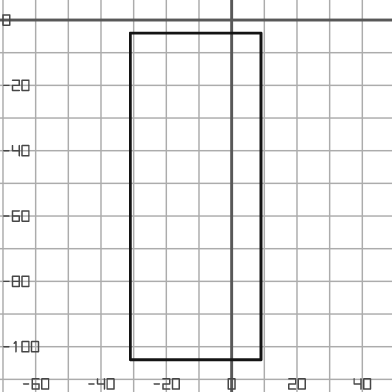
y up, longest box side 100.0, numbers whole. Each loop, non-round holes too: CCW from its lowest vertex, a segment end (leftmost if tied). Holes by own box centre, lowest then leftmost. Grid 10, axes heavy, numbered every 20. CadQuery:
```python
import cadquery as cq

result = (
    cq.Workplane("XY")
    .moveTo(-31.0, -104.0)
    .lineTo(9.0, -104.0)
    .lineTo(9.0, -4.0)
    .lineTo(-31.0, -4.0)
    .close()
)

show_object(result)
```